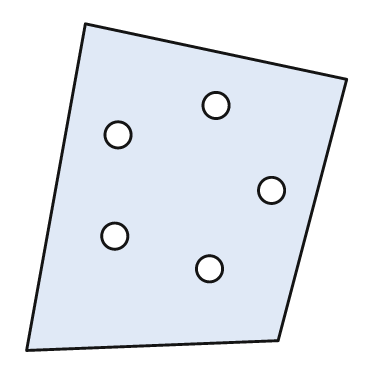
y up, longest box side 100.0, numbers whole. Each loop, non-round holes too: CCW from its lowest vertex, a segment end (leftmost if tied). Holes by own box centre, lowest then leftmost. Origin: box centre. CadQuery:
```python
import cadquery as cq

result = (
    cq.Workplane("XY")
    .moveTo(-49.0, -50.0)
    .lineTo(28.0, -47.0)
    .lineTo(49.0, 33.0)
    .lineTo(-31.0, 50.0)
    .close()
    .moveTo(7.0, -25.0)
    .circle(4.0)
    .moveTo(-22.0, -15.0)
    .circle(4.0)
    .moveTo(26.0, -1.0)
    .circle(4.0)
    .moveTo(-21.0, 16.0)
    .circle(4.0)
    .moveTo(9.0, 25.0)
    .circle(4.0)
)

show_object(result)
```